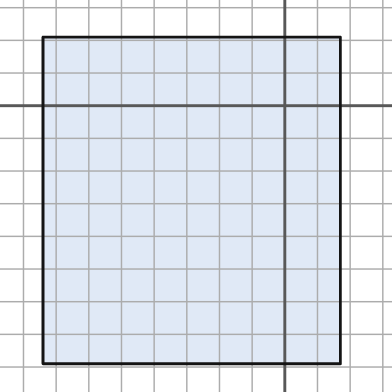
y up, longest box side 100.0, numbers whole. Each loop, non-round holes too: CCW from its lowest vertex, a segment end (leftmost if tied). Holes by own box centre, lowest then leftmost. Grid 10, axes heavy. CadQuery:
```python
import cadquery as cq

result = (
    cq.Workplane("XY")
    .moveTo(-74.0, -79.0)
    .lineTo(17.0, -79.0)
    .lineTo(17.0, 21.0)
    .lineTo(-74.0, 21.0)
    .close()
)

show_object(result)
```